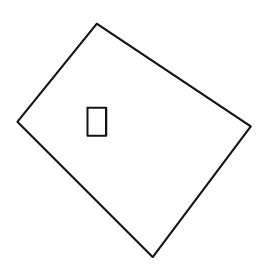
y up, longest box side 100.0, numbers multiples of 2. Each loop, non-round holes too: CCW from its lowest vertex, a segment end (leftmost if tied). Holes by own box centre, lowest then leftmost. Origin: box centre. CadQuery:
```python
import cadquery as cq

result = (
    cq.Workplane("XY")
    .moveTo(8.0, -50.0)
    .lineTo(50.0, 6.0)
    .lineTo(-16.0, 50.0)
    .lineTo(-50.0, 8.0)
    .close()
    .moveTo(-20.0, 2.0)
    .lineTo(-12.0, 2.0)
    .lineTo(-12.0, 14.0)
    .lineTo(-20.0, 14.0)
    .close()
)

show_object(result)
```